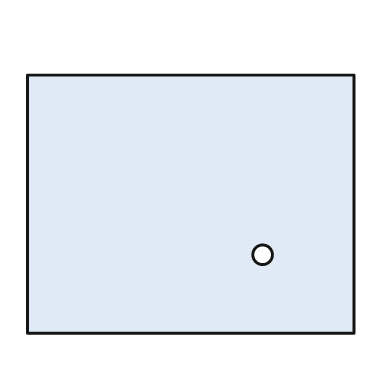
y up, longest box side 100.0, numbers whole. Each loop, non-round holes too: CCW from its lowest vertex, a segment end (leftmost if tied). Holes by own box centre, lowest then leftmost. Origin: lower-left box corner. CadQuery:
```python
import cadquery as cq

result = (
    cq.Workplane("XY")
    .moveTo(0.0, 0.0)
    .lineTo(100.0, 0.0)
    .lineTo(100.0, 79.0)
    .lineTo(0.0, 79.0)
    .close()
    .moveTo(72.0, 24.0)
    .circle(3.0)
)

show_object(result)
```